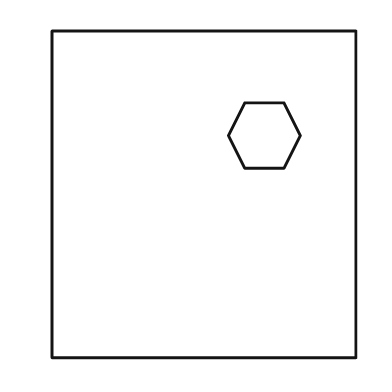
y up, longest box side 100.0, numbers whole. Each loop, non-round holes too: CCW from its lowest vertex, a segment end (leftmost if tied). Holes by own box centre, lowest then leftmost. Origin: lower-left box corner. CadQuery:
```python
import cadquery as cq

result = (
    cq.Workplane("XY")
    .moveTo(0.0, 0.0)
    .lineTo(93.0, 0.0)
    .lineTo(93.0, 100.0)
    .lineTo(0.0, 100.0)
    .close()
    .moveTo(59.0, 58.0)
    .lineTo(71.0, 58.0)
    .lineTo(76.0, 68.0)
    .lineTo(71.0, 78.0)
    .lineTo(59.0, 78.0)
    .lineTo(54.0, 68.0)
    .close()
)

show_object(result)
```